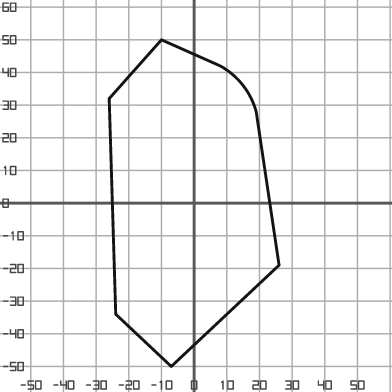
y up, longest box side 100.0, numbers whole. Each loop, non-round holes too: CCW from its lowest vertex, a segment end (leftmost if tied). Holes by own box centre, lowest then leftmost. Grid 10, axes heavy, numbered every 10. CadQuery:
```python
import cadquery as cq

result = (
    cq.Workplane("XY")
    .moveTo(-7.0, -50.0)
    .lineTo(26.0, -19.0)
    .lineTo(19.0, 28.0)
    .threePointArc((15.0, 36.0), (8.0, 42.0))
    .lineTo(-10.0, 50.0)
    .lineTo(-26.0, 32.0)
    .lineTo(-24.0, -34.0)
    .close()
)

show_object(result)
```